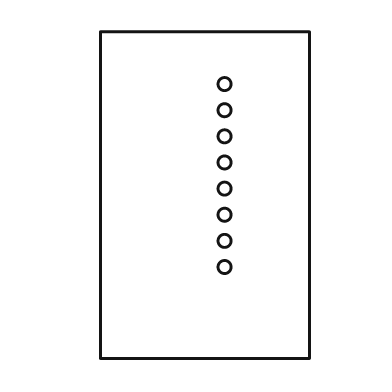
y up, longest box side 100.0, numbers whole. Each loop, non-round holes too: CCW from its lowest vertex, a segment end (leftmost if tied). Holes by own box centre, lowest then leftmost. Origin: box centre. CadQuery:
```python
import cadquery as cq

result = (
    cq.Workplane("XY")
    .moveTo(-32.0, -50.0)
    .lineTo(32.0, -50.0)
    .lineTo(32.0, 50.0)
    .lineTo(-32.0, 50.0)
    .close()
    .moveTo(6.0, -22.0)
    .circle(2.0)
    .moveTo(6.0, -14.0)
    .circle(2.0)
    .moveTo(6.0, -6.0)
    .circle(2.0)
    .moveTo(6.0, 2.0)
    .circle(2.0)
    .moveTo(6.0, 10.0)
    .circle(2.0)
    .moveTo(6.0, 18.0)
    .circle(2.0)
    .moveTo(6.0, 26.0)
    .circle(2.0)
    .moveTo(6.0, 34.0)
    .circle(2.0)
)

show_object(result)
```